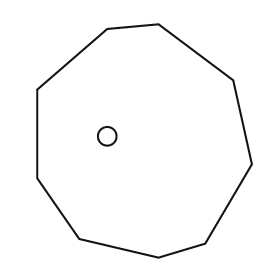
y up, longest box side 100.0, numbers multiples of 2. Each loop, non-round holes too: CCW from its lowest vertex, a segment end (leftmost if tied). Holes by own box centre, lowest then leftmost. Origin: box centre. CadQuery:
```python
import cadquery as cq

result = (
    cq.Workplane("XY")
    .moveTo(6.0, -50.0)
    .lineTo(26.0, -44.0)
    .lineTo(46.0, -10.0)
    .lineTo(38.0, 26.0)
    .lineTo(6.0, 50.0)
    .lineTo(-16.0, 48.0)
    .lineTo(-46.0, 22.0)
    .lineTo(-46.0, -16.0)
    .lineTo(-28.0, -42.0)
    .close()
    .moveTo(-16.0, 2.0)
    .circle(4.0)
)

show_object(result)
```